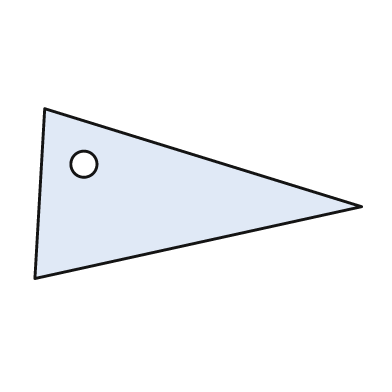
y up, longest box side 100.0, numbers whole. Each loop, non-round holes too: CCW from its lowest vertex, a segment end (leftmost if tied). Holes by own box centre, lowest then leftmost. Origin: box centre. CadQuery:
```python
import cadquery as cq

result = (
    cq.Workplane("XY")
    .moveTo(-50.0, -26.0)
    .lineTo(50.0, -4.0)
    .lineTo(-47.0, 26.0)
    .close()
    .moveTo(-35.0, 9.0)
    .circle(4.0)
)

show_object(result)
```